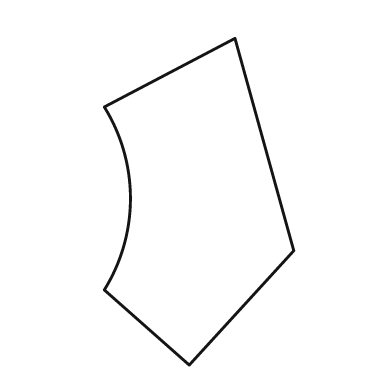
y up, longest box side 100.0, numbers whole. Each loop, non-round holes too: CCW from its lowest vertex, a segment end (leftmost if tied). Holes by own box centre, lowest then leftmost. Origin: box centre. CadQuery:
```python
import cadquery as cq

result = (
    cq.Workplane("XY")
    .moveTo(-3.0, -50.0)
    .lineTo(29.0, -15.0)
    .lineTo(11.0, 50.0)
    .lineTo(-29.0, 29.0)
    .threePointArc((-21.0, 1.0), (-29.0, -27.0))
    .close()
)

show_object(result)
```